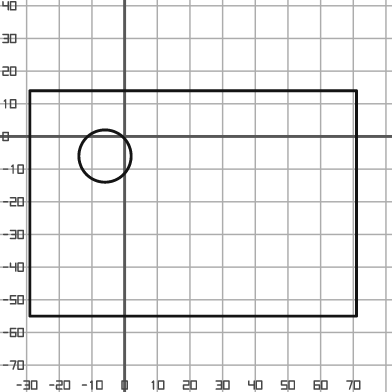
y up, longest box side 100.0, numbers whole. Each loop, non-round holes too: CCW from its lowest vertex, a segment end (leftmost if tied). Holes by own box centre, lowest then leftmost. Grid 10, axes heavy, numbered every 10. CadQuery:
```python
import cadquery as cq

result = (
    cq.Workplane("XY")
    .moveTo(-29.0, -55.0)
    .lineTo(71.0, -55.0)
    .lineTo(71.0, 14.0)
    .lineTo(-29.0, 14.0)
    .close()
    .moveTo(-6.0, -6.0)
    .circle(8.0)
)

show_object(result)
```